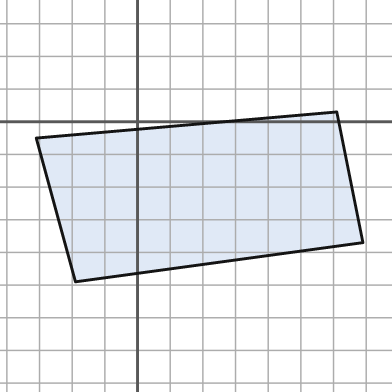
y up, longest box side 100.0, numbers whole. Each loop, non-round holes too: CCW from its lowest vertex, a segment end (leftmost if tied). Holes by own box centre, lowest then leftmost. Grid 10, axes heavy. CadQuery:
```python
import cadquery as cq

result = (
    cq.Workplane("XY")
    .moveTo(-19.0, -49.0)
    .lineTo(69.0, -37.0)
    .lineTo(61.0, 3.0)
    .lineTo(-31.0, -5.0)
    .close()
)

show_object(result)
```